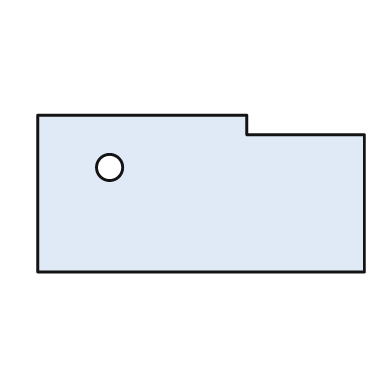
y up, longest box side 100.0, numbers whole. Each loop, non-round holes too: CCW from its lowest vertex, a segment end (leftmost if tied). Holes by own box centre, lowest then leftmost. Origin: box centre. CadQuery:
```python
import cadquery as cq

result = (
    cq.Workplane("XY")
    .moveTo(-50.0, -24.0)
    .lineTo(50.0, -24.0)
    .lineTo(50.0, 18.0)
    .lineTo(14.0, 18.0)
    .lineTo(14.0, 24.0)
    .lineTo(-50.0, 24.0)
    .close()
    .moveTo(-28.0, 8.0)
    .circle(4.0)
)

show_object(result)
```